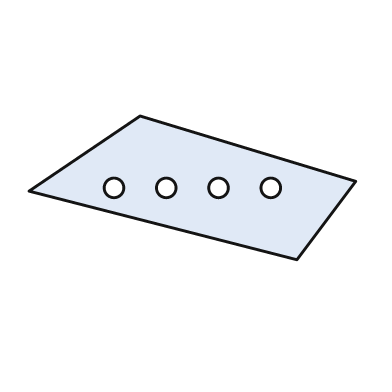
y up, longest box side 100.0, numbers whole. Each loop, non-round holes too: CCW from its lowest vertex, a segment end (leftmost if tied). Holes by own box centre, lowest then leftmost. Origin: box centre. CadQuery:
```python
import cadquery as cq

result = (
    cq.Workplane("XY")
    .moveTo(32.0, -22.0)
    .lineTo(50.0, 2.0)
    .lineTo(-16.0, 22.0)
    .lineTo(-50.0, -1.0)
    .close()
    .moveTo(-24.0, 0.0)
    .circle(3.0)
    .moveTo(-8.0, 0.0)
    .circle(3.0)
    .moveTo(8.0, 0.0)
    .circle(3.0)
    .moveTo(24.0, 0.0)
    .circle(3.0)
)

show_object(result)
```